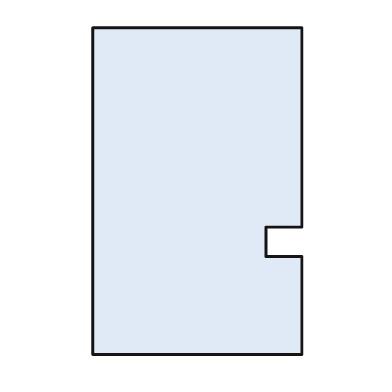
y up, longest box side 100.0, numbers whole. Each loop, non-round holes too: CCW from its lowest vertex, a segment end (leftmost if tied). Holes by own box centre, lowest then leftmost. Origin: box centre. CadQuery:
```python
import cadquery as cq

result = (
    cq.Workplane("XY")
    .moveTo(-32.0, -50.0)
    .lineTo(32.0, -50.0)
    .lineTo(32.0, -20.0)
    .lineTo(21.0, -20.0)
    .lineTo(21.0, -11.0)
    .lineTo(32.0, -11.0)
    .lineTo(32.0, 50.0)
    .lineTo(-32.0, 50.0)
    .close()
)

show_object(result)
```